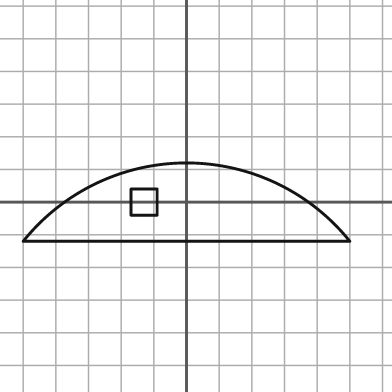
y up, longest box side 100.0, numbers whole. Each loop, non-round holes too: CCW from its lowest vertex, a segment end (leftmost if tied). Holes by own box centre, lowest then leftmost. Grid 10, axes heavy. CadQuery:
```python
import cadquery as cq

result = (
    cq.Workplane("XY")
    .moveTo(-50.0, -12.0)
    .lineTo(50.0, -12.0)
    .threePointArc((0.0, 12.0), (-50.0, -12.0))
    .close()
    .moveTo(-17.0, -4.0)
    .lineTo(-9.0, -4.0)
    .lineTo(-9.0, 4.0)
    .lineTo(-17.0, 4.0)
    .close()
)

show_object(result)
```